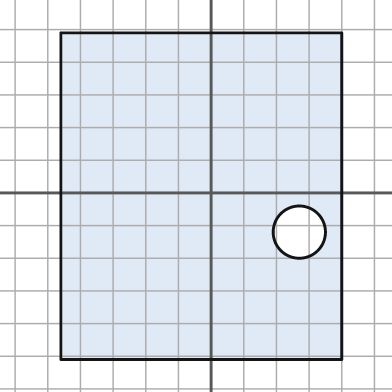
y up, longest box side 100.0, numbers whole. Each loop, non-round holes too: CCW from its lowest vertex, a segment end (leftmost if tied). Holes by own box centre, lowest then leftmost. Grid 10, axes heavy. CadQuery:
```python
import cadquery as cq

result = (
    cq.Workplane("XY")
    .moveTo(-46.0, -51.0)
    .lineTo(40.0, -51.0)
    .lineTo(40.0, 49.0)
    .lineTo(-46.0, 49.0)
    .close()
    .moveTo(27.0, -12.0)
    .circle(8.0)
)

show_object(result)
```